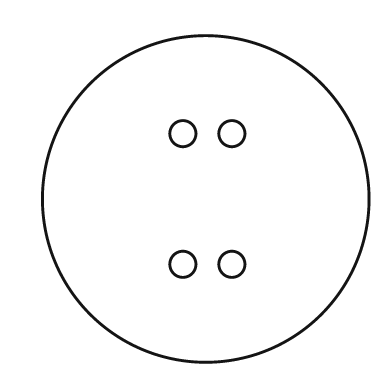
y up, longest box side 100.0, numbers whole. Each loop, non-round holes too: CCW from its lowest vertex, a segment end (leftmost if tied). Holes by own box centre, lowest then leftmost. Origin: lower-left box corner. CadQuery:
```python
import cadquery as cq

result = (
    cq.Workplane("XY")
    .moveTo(50.0, 50.0)
    .circle(50.0)
    .moveTo(43.0, 30.0)
    .circle(4.0)
    .moveTo(58.0, 30.0)
    .circle(4.0)
    .moveTo(43.0, 70.0)
    .circle(4.0)
    .moveTo(58.0, 70.0)
    .circle(4.0)
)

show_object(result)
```